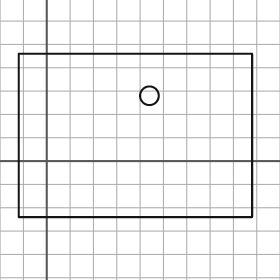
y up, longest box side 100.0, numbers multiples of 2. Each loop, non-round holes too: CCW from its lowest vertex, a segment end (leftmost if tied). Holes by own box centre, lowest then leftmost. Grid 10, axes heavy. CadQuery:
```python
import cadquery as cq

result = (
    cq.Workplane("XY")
    .moveTo(-12.0, -24.0)
    .lineTo(88.0, -24.0)
    .lineTo(88.0, 46.0)
    .lineTo(-12.0, 46.0)
    .close()
    .moveTo(44.0, 28.0)
    .circle(4.0)
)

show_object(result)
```